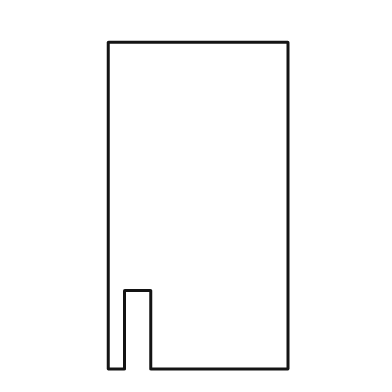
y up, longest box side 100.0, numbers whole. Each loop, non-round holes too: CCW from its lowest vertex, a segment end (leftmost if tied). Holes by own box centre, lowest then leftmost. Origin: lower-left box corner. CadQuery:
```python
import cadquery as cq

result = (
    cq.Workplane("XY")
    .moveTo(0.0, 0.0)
    .lineTo(5.0, 0.0)
    .lineTo(5.0, 24.0)
    .lineTo(13.0, 24.0)
    .lineTo(13.0, 0.0)
    .lineTo(55.0, 0.0)
    .lineTo(55.0, 100.0)
    .lineTo(0.0, 100.0)
    .close()
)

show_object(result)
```